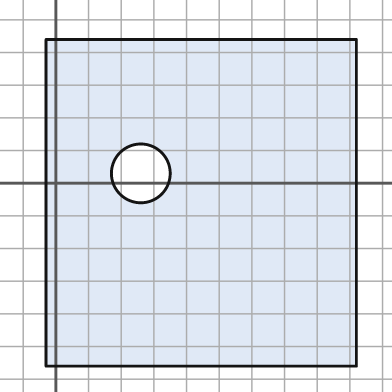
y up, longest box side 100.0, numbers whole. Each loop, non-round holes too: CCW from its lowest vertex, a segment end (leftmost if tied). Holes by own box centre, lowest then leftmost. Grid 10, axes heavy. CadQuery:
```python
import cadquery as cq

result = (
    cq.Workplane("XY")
    .moveTo(-3.0, -56.0)
    .lineTo(92.0, -56.0)
    .lineTo(92.0, 44.0)
    .lineTo(-3.0, 44.0)
    .close()
    .moveTo(26.0, 3.0)
    .circle(9.0)
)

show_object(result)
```